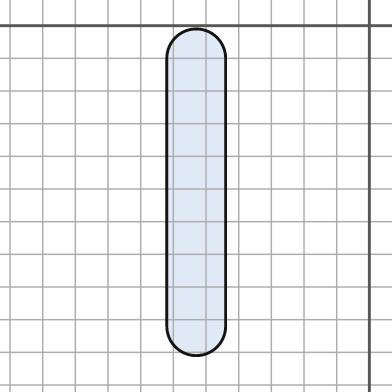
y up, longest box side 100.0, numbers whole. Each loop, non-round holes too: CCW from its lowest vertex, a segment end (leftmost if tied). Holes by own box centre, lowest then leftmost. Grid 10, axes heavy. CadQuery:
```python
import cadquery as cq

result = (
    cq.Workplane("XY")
    .moveTo(-62.0, -92.0)
    .threePointArc((-53.0, -101.0), (-44.0, -92.0))
    .lineTo(-44.0, -10.0)
    .threePointArc((-53.0, -1.0), (-62.0, -10.0))
    .close()
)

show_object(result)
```